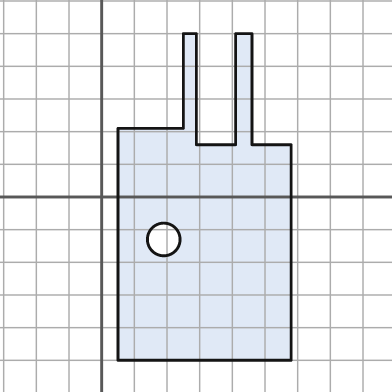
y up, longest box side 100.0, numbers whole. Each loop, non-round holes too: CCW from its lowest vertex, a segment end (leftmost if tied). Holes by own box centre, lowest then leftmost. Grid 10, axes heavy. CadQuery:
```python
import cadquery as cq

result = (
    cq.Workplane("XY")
    .moveTo(5.0, -50.0)
    .lineTo(58.0, -50.0)
    .lineTo(58.0, 16.0)
    .lineTo(46.0, 16.0)
    .lineTo(46.0, 50.0)
    .lineTo(41.0, 50.0)
    .lineTo(41.0, 16.0)
    .lineTo(29.0, 16.0)
    .lineTo(29.0, 50.0)
    .lineTo(25.0, 50.0)
    .lineTo(25.0, 21.0)
    .lineTo(5.0, 21.0)
    .close()
    .moveTo(19.0, -13.0)
    .circle(5.0)
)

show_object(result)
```